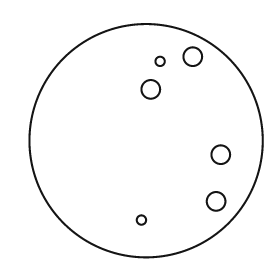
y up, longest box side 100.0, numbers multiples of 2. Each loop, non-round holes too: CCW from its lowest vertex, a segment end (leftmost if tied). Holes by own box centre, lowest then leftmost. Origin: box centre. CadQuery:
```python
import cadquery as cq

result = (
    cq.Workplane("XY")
    .moveTo(0.0, 0.0)
    .circle(50.0)
    .moveTo(-2.0, -34.0)
    .circle(2.0)
    .moveTo(30.0, -26.0)
    .circle(4.0)
    .moveTo(32.0, -6.0)
    .circle(4.0)
    .moveTo(2.0, 22.0)
    .circle(4.0)
    .moveTo(6.0, 34.0)
    .circle(2.0)
    .moveTo(20.0, 36.0)
    .circle(4.0)
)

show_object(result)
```